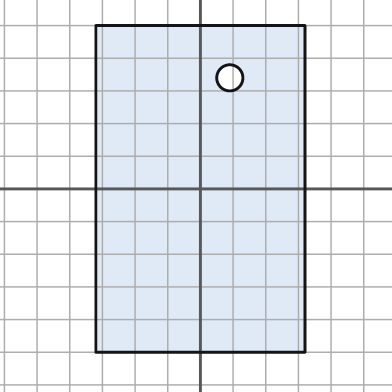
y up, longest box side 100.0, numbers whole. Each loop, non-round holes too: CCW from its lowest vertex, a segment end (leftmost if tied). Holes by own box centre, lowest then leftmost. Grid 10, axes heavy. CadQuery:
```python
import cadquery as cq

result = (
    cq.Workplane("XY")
    .moveTo(-32.0, -50.0)
    .lineTo(32.0, -50.0)
    .lineTo(32.0, 50.0)
    .lineTo(-32.0, 50.0)
    .close()
    .moveTo(9.0, 34.0)
    .circle(4.0)
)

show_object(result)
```